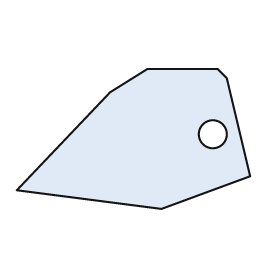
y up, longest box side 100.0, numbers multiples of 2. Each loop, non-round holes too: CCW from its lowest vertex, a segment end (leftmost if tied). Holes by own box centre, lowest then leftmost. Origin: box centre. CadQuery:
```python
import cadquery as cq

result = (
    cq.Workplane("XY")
    .moveTo(12.0, -30.0)
    .lineTo(50.0, -16.0)
    .lineTo(40.0, 26.0)
    .lineTo(36.0, 30.0)
    .lineTo(6.0, 30.0)
    .lineTo(-10.0, 20.0)
    .lineTo(-50.0, -22.0)
    .close()
    .moveTo(34.0, 2.0)
    .circle(6.0)
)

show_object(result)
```